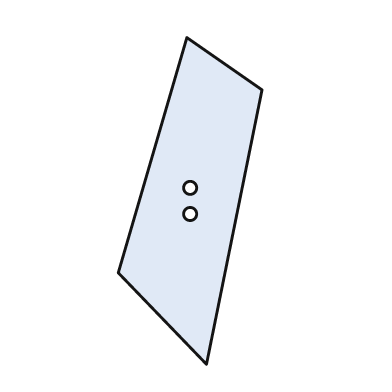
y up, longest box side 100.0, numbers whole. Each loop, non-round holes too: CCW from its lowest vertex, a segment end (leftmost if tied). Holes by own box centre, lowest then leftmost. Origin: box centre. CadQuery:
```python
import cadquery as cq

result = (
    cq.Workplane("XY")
    .moveTo(5.0, -50.0)
    .lineTo(22.0, 34.0)
    .lineTo(-1.0, 50.0)
    .lineTo(-22.0, -22.0)
    .close()
    .moveTo(0.0, -4.0)
    .circle(2.0)
    .moveTo(0.0, 4.0)
    .circle(2.0)
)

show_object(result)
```